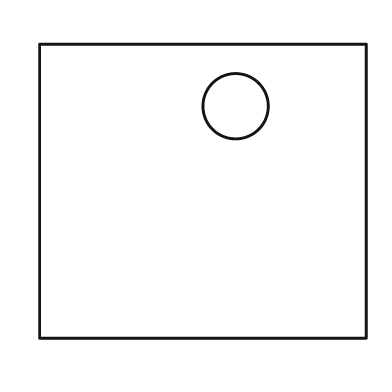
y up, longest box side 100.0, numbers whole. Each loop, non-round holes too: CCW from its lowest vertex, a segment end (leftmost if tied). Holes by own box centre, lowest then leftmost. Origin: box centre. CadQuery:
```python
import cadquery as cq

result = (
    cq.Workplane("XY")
    .moveTo(-50.0, -45.0)
    .lineTo(50.0, -45.0)
    .lineTo(50.0, 45.0)
    .lineTo(-50.0, 45.0)
    .close()
    .moveTo(10.0, 26.0)
    .circle(10.0)
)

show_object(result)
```